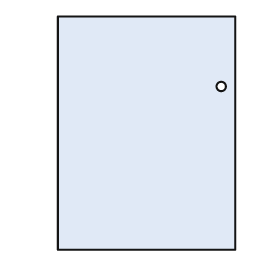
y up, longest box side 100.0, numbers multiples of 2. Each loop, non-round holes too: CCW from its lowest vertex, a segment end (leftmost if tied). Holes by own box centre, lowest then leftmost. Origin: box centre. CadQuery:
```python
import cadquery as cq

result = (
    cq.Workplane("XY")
    .moveTo(-38.0, -50.0)
    .lineTo(38.0, -50.0)
    .lineTo(38.0, 50.0)
    .lineTo(-38.0, 50.0)
    .close()
    .moveTo(32.0, 20.0)
    .circle(2.0)
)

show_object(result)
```